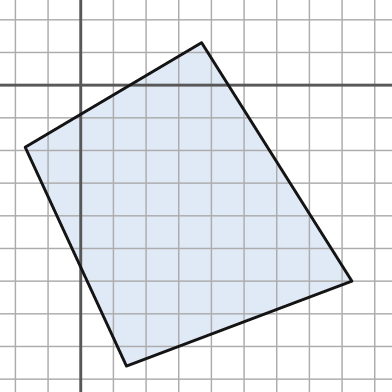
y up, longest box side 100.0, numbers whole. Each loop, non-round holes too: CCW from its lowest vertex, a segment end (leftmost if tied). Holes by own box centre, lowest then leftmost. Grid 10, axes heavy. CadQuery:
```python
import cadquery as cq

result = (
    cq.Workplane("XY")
    .moveTo(14.0, -86.0)
    .lineTo(83.0, -60.0)
    .lineTo(37.0, 13.0)
    .lineTo(-17.0, -19.0)
    .close()
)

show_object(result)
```